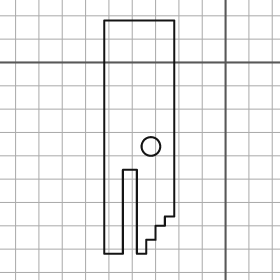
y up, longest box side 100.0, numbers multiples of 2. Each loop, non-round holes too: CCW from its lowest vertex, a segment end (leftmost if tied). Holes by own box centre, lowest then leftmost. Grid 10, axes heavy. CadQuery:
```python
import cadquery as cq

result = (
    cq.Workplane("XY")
    .moveTo(-52.0, -82.0)
    .lineTo(-44.0, -82.0)
    .lineTo(-44.0, -46.0)
    .lineTo(-38.0, -46.0)
    .lineTo(-38.0, -82.0)
    .lineTo(-34.0, -82.0)
    .lineTo(-34.0, -76.0)
    .lineTo(-30.0, -76.0)
    .lineTo(-30.0, -70.0)
    .lineTo(-26.0, -70.0)
    .lineTo(-26.0, -66.0)
    .lineTo(-22.0, -66.0)
    .lineTo(-22.0, 18.0)
    .lineTo(-52.0, 18.0)
    .close()
    .moveTo(-32.0, -36.0)
    .circle(4.0)
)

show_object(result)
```